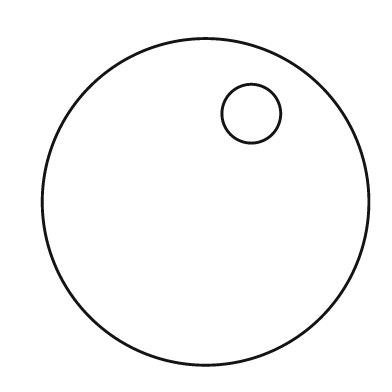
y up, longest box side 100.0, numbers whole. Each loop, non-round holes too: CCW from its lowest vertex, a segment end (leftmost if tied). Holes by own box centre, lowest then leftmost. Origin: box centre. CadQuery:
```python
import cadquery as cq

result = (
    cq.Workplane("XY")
    .moveTo(0.0, 0.0)
    .circle(50.0)
    .moveTo(14.0, 27.0)
    .circle(9.0)
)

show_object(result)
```